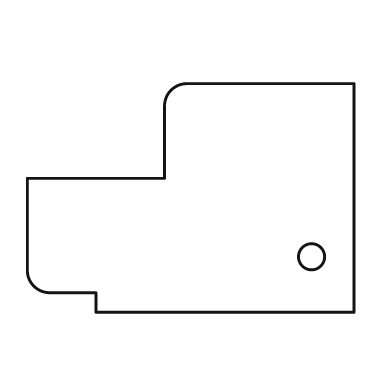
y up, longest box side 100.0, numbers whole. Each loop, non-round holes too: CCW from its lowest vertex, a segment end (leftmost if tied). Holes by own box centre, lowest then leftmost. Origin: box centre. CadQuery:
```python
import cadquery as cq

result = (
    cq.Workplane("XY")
    .moveTo(-29.0, -35.0)
    .lineTo(50.0, -35.0)
    .lineTo(50.0, 35.0)
    .lineTo(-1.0, 35.0)
    .threePointArc((-6.0, 33.0), (-8.0, 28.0))
    .lineTo(-8.0, 6.0)
    .lineTo(-50.0, 6.0)
    .lineTo(-50.0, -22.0)
    .threePointArc((-48.0, -27.0), (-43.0, -29.0))
    .lineTo(-29.0, -29.0)
    .close()
    .moveTo(37.0, -18.0)
    .circle(4.0)
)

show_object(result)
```